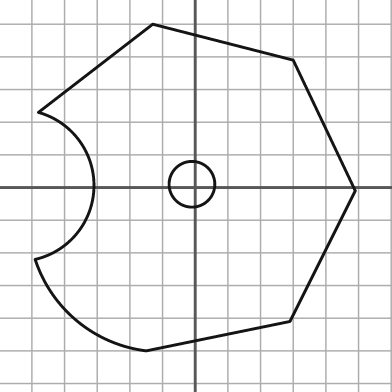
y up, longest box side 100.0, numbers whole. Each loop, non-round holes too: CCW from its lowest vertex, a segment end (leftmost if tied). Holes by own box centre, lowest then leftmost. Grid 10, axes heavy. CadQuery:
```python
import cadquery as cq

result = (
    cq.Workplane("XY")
    .moveTo(-15.0, -50.0)
    .lineTo(29.0, -41.0)
    .lineTo(49.0, -1.0)
    .lineTo(30.0, 39.0)
    .lineTo(-13.0, 50.0)
    .lineTo(-48.0, 23.0)
    .threePointArc((-31.0, 0.0), (-49.0, -22.0))
    .threePointArc((-36.0, -41.0), (-15.0, -50.0))
    .close()
    .moveTo(-1.0, 1.0)
    .circle(7.0)
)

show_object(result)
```